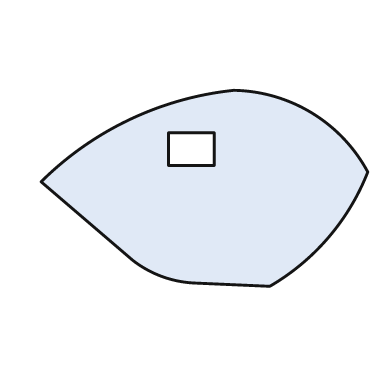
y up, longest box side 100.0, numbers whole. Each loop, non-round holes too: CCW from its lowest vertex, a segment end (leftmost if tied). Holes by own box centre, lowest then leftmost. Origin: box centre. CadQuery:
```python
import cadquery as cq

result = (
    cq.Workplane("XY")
    .moveTo(20.0, -30.0)
    .threePointArc((38.0, -15.0), (50.0, 5.0))
    .threePointArc((33.0, 23.0), (9.0, 30.0))
    .threePointArc((-23.0, 21.0), (-50.0, 2.0))
    .lineTo(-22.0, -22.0)
    .threePointArc((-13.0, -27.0), (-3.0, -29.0))
    .close()
    .moveTo(-11.0, 7.0)
    .lineTo(3.0, 7.0)
    .lineTo(3.0, 17.0)
    .lineTo(-11.0, 17.0)
    .close()
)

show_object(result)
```